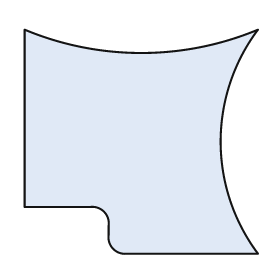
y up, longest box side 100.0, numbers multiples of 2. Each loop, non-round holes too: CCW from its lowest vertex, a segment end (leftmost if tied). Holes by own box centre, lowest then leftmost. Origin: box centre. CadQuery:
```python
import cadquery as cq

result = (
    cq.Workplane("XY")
    .moveTo(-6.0, -48.0)
    .lineTo(50.0, -48.0)
    .threePointArc((34.0, 0.0), (50.0, 48.0))
    .threePointArc((0.0, 38.0), (-50.0, 48.0))
    .lineTo(-50.0, -28.0)
    .lineTo(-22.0, -28.0)
    .threePointArc((-16.0, -30.0), (-14.0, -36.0))
    .lineTo(-14.0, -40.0)
    .threePointArc((-12.0, -46.0), (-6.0, -48.0))
    .close()
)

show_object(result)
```